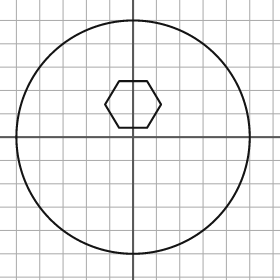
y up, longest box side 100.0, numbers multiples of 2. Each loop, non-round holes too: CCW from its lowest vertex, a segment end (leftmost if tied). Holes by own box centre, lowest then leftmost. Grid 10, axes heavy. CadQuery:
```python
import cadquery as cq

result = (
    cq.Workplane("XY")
    .moveTo(0.0, 0.0)
    .circle(50.0)
    .moveTo(-6.0, 4.0)
    .lineTo(6.0, 4.0)
    .lineTo(12.0, 14.0)
    .lineTo(6.0, 24.0)
    .lineTo(-6.0, 24.0)
    .lineTo(-12.0, 14.0)
    .close()
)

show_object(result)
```